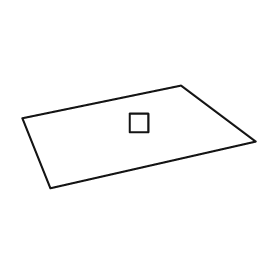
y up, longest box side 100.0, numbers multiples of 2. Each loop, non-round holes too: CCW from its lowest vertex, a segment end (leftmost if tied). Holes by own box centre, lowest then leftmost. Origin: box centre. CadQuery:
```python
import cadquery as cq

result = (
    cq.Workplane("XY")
    .moveTo(-38.0, -22.0)
    .lineTo(50.0, -2.0)
    .lineTo(18.0, 22.0)
    .lineTo(-50.0, 8.0)
    .close()
    .moveTo(-4.0, 2.0)
    .lineTo(4.0, 2.0)
    .lineTo(4.0, 10.0)
    .lineTo(-4.0, 10.0)
    .close()
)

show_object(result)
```